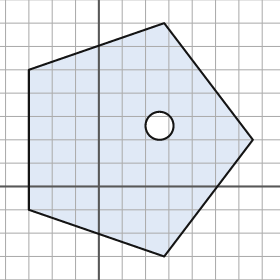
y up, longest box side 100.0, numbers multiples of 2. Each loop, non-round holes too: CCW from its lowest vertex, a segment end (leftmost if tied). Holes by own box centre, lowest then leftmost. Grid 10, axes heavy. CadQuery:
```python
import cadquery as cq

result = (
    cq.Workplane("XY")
    .moveTo(28.0, -30.0)
    .lineTo(66.0, 20.0)
    .lineTo(28.0, 70.0)
    .lineTo(-30.0, 50.0)
    .lineTo(-30.0, -10.0)
    .close()
    .moveTo(26.0, 26.0)
    .circle(6.0)
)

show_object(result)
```